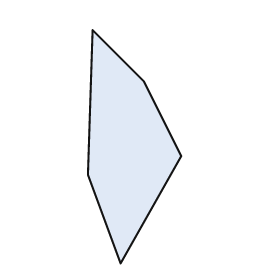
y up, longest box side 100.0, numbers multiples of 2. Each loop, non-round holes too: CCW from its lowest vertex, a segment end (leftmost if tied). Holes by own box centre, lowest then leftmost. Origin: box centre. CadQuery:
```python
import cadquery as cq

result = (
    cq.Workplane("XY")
    .moveTo(-6.0, -50.0)
    .lineTo(20.0, -4.0)
    .lineTo(4.0, 28.0)
    .lineTo(-18.0, 50.0)
    .lineTo(-20.0, -12.0)
    .close()
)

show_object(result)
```